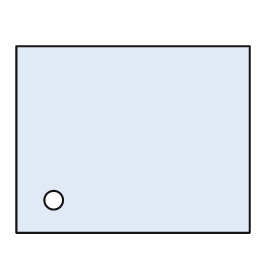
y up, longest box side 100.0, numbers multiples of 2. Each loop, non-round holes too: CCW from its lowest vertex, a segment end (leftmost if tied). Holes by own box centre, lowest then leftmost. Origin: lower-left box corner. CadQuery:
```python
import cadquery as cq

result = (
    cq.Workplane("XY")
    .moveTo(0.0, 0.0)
    .lineTo(100.0, 0.0)
    .lineTo(100.0, 80.0)
    .lineTo(0.0, 80.0)
    .close()
    .moveTo(16.0, 14.0)
    .circle(4.0)
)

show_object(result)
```